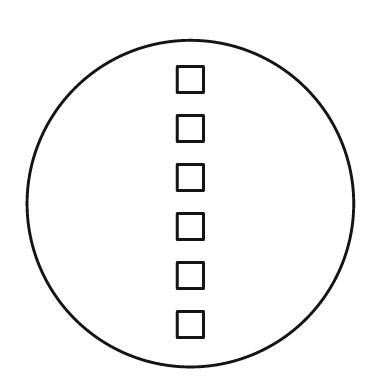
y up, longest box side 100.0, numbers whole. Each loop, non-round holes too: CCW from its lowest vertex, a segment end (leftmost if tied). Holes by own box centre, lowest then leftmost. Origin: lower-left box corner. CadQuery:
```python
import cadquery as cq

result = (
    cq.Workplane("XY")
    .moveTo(50.0, 50.0)
    .circle(50.0)
    .moveTo(46.0, 9.0)
    .lineTo(54.0, 9.0)
    .lineTo(54.0, 17.0)
    .lineTo(46.0, 17.0)
    .close()
    .moveTo(46.0, 24.0)
    .lineTo(54.0, 24.0)
    .lineTo(54.0, 32.0)
    .lineTo(46.0, 32.0)
    .close()
    .moveTo(46.0, 39.0)
    .lineTo(54.0, 39.0)
    .lineTo(54.0, 47.0)
    .lineTo(46.0, 47.0)
    .close()
    .moveTo(46.0, 54.0)
    .lineTo(54.0, 54.0)
    .lineTo(54.0, 62.0)
    .lineTo(46.0, 62.0)
    .close()
    .moveTo(46.0, 69.0)
    .lineTo(54.0, 69.0)
    .lineTo(54.0, 77.0)
    .lineTo(46.0, 77.0)
    .close()
    .moveTo(46.0, 84.0)
    .lineTo(54.0, 84.0)
    .lineTo(54.0, 92.0)
    .lineTo(46.0, 92.0)
    .close()
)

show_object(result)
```